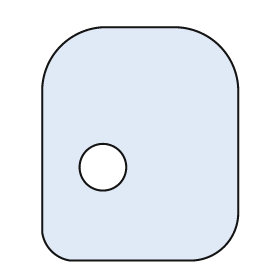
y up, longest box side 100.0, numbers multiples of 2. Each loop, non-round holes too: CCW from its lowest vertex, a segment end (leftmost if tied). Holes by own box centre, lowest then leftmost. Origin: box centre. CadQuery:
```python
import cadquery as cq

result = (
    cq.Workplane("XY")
    .moveTo(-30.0, -50.0)
    .lineTo(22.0, -50.0)
    .threePointArc((36.0, -44.0), (42.0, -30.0))
    .lineTo(42.0, 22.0)
    .threePointArc((34.0, 42.0), (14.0, 50.0))
    .lineTo(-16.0, 50.0)
    .threePointArc((-34.0, 42.0), (-42.0, 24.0))
    .lineTo(-42.0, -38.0)
    .threePointArc((-38.0, -46.0), (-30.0, -50.0))
    .close()
    .moveTo(-16.0, -10.0)
    .circle(10.0)
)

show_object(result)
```